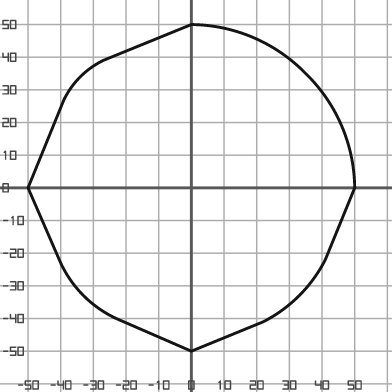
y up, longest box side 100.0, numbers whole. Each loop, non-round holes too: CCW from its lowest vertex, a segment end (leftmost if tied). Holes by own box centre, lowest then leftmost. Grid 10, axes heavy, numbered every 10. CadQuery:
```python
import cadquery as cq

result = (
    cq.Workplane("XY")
    .moveTo(0.0, -50.0)
    .lineTo(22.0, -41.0)
    .threePointArc((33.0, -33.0), (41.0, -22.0))
    .lineTo(50.0, 0.0)
    .threePointArc((46.0, 19.0), (35.0, 35.0))
    .threePointArc((19.0, 46.0), (0.0, 50.0))
    .lineTo(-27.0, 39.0)
    .threePointArc((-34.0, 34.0), (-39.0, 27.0))
    .lineTo(-50.0, 0.0)
    .lineTo(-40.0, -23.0)
    .threePointArc((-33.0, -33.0), (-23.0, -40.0))
    .close()
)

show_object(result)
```